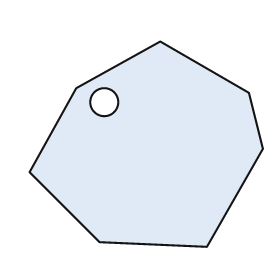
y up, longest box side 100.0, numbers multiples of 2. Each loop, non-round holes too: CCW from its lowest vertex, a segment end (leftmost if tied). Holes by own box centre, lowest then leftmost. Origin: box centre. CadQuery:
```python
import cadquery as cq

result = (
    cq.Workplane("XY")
    .moveTo(26.0, -44.0)
    .lineTo(50.0, -2.0)
    .lineTo(44.0, 22.0)
    .lineTo(6.0, 44.0)
    .lineTo(-30.0, 24.0)
    .lineTo(-50.0, -12.0)
    .lineTo(-20.0, -42.0)
    .close()
    .moveTo(-18.0, 18.0)
    .circle(6.0)
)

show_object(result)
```